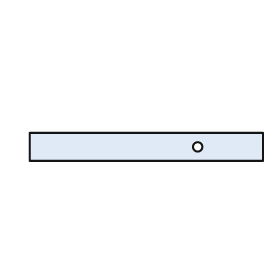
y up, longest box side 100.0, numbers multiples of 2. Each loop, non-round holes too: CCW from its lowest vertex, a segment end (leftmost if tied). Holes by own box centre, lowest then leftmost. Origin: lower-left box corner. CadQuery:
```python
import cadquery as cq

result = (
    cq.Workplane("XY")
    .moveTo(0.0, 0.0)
    .lineTo(100.0, 0.0)
    .lineTo(100.0, 12.0)
    .lineTo(0.0, 12.0)
    .close()
    .moveTo(72.0, 6.0)
    .circle(2.0)
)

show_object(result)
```